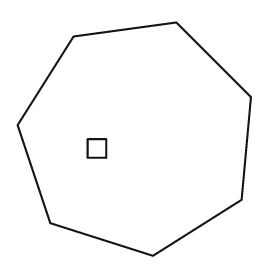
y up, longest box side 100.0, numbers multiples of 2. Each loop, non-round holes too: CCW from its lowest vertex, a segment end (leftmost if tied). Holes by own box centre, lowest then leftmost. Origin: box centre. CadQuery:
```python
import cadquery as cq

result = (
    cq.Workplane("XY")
    .moveTo(8.0, -50.0)
    .lineTo(46.0, -26.0)
    .lineTo(50.0, 18.0)
    .lineTo(18.0, 50.0)
    .lineTo(-26.0, 44.0)
    .lineTo(-50.0, 6.0)
    .lineTo(-36.0, -36.0)
    .close()
    .moveTo(-20.0, -8.0)
    .lineTo(-12.0, -8.0)
    .lineTo(-12.0, 0.0)
    .lineTo(-20.0, 0.0)
    .close()
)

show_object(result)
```